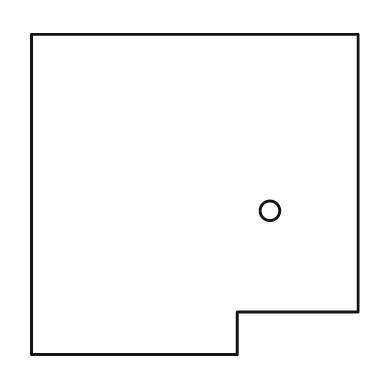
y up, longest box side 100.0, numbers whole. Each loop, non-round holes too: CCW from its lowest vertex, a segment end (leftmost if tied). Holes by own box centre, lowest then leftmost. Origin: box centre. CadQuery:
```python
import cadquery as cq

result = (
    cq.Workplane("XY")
    .moveTo(-50.0, -49.0)
    .lineTo(13.0, -49.0)
    .lineTo(13.0, -36.0)
    .lineTo(50.0, -36.0)
    .lineTo(50.0, 49.0)
    .lineTo(-50.0, 49.0)
    .close()
    .moveTo(23.0, -5.0)
    .circle(3.0)
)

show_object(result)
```